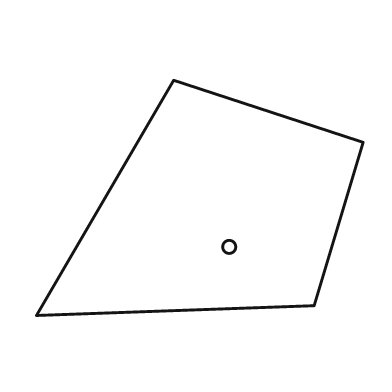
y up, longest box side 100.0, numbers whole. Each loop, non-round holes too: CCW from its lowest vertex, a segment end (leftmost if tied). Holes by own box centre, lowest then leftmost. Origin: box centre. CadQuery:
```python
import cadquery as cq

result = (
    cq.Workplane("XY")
    .moveTo(-50.0, -36.0)
    .lineTo(35.0, -33.0)
    .lineTo(50.0, 17.0)
    .lineTo(-8.0, 36.0)
    .close()
    .moveTo(9.0, -15.0)
    .circle(2.0)
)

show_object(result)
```